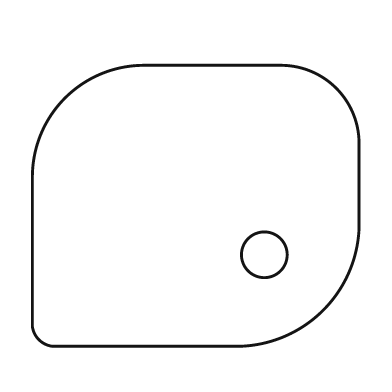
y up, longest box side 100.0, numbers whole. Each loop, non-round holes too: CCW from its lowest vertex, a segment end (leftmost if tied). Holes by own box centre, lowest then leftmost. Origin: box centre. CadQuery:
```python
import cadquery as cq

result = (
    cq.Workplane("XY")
    .moveTo(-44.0, -43.0)
    .lineTo(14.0, -43.0)
    .threePointArc((39.0, -32.0), (50.0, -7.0))
    .lineTo(50.0, 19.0)
    .threePointArc((43.0, 36.0), (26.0, 43.0))
    .lineTo(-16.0, 43.0)
    .threePointArc((-40.0, 33.0), (-50.0, 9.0))
    .lineTo(-50.0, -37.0)
    .threePointArc((-48.0, -41.0), (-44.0, -43.0))
    .close()
    .moveTo(21.0, -15.0)
    .circle(7.0)
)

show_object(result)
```